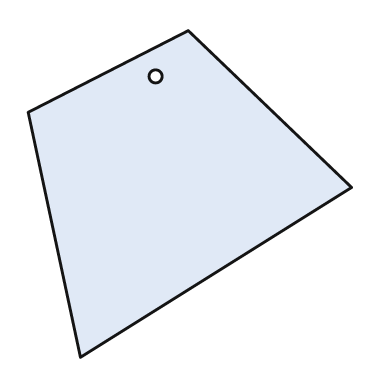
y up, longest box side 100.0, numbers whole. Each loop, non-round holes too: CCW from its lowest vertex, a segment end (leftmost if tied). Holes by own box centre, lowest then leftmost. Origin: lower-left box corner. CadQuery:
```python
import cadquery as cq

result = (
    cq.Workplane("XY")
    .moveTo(16.0, 0.0)
    .lineTo(99.0, 52.0)
    .lineTo(49.0, 100.0)
    .lineTo(0.0, 75.0)
    .close()
    .moveTo(39.0, 86.0)
    .circle(2.0)
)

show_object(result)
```